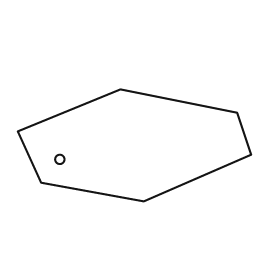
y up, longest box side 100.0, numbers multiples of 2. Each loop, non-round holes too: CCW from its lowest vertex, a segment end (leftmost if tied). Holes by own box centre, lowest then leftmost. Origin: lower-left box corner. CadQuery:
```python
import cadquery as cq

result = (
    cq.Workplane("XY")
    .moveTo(54.0, 0.0)
    .lineTo(100.0, 20.0)
    .lineTo(94.0, 38.0)
    .lineTo(44.0, 48.0)
    .lineTo(0.0, 30.0)
    .lineTo(10.0, 8.0)
    .close()
    .moveTo(18.0, 18.0)
    .circle(2.0)
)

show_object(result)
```